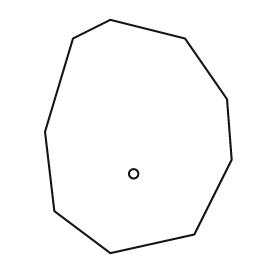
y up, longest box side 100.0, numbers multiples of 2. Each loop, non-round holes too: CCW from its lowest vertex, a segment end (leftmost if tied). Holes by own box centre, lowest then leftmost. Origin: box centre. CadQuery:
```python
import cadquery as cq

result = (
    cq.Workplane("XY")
    .moveTo(-12.0, -50.0)
    .lineTo(24.0, -42.0)
    .lineTo(40.0, -10.0)
    .lineTo(38.0, 16.0)
    .lineTo(20.0, 42.0)
    .lineTo(-12.0, 50.0)
    .lineTo(-28.0, 42.0)
    .lineTo(-40.0, 2.0)
    .lineTo(-36.0, -32.0)
    .close()
    .moveTo(-2.0, -16.0)
    .circle(2.0)
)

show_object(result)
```